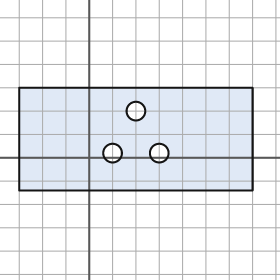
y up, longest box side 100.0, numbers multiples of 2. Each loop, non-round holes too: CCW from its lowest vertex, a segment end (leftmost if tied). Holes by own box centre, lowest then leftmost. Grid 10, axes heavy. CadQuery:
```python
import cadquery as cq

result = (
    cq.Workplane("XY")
    .moveTo(-30.0, -14.0)
    .lineTo(70.0, -14.0)
    .lineTo(70.0, 30.0)
    .lineTo(-30.0, 30.0)
    .close()
    .moveTo(10.0, 2.0)
    .circle(4.0)
    .moveTo(30.0, 2.0)
    .circle(4.0)
    .moveTo(20.0, 20.0)
    .circle(4.0)
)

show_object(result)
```